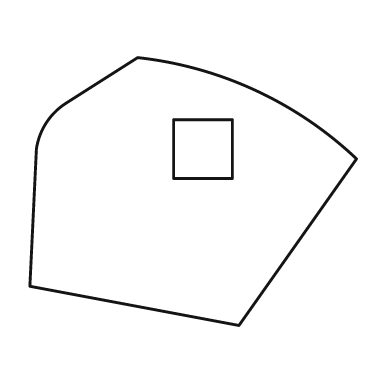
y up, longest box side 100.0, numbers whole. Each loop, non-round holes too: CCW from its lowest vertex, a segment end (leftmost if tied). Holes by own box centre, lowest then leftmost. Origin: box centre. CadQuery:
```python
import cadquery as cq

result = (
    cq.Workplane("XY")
    .moveTo(14.0, -41.0)
    .lineTo(50.0, 10.0)
    .threePointArc((19.0, 31.0), (-17.0, 41.0))
    .lineTo(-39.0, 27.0)
    .threePointArc((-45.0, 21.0), (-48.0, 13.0))
    .lineTo(-50.0, -29.0)
    .close()
    .moveTo(-6.0, 4.0)
    .lineTo(12.0, 4.0)
    .lineTo(12.0, 22.0)
    .lineTo(-6.0, 22.0)
    .close()
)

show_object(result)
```